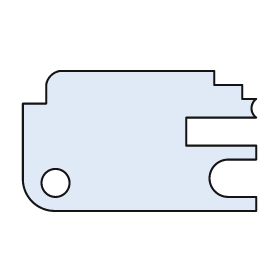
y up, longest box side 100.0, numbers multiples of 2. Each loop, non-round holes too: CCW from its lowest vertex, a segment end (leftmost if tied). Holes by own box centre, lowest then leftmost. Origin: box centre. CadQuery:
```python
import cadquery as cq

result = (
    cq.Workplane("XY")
    .moveTo(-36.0, -30.0)
    .lineTo(50.0, -30.0)
    .lineTo(50.0, -24.0)
    .lineTo(38.0, -24.0)
    .threePointArc((30.0, -16.0), (38.0, -8.0))
    .lineTo(50.0, -8.0)
    .lineTo(50.0, -2.0)
    .lineTo(20.0, -2.0)
    .lineTo(20.0, 10.0)
    .lineTo(50.0, 10.0)
    .threePointArc((48.0, 14.0), (50.0, 18.0))
    .lineTo(44.0, 18.0)
    .lineTo(44.0, 24.0)
    .lineTo(32.0, 24.0)
    .lineTo(32.0, 30.0)
    .lineTo(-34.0, 30.0)
    .threePointArc((-38.0, 28.0), (-40.0, 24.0))
    .lineTo(-40.0, 16.0)
    .lineTo(-50.0, 16.0)
    .lineTo(-50.0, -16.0)
    .threePointArc((-46.0, -26.0), (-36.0, -30.0))
    .close()
    .moveTo(-36.0, -18.0)
    .circle(6.0)
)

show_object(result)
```